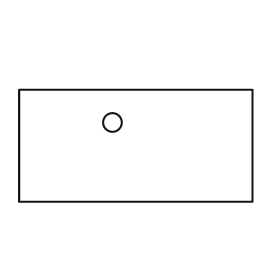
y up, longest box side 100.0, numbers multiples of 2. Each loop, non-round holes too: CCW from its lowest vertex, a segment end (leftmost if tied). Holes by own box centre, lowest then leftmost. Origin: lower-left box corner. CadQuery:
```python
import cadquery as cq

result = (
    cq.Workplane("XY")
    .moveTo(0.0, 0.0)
    .lineTo(100.0, 0.0)
    .lineTo(100.0, 48.0)
    .lineTo(0.0, 48.0)
    .close()
    .moveTo(40.0, 34.0)
    .circle(4.0)
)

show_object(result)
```